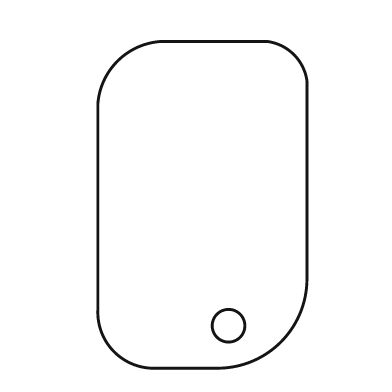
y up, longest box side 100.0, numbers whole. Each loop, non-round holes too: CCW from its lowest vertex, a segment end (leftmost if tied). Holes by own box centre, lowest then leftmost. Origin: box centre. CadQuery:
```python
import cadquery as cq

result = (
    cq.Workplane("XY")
    .moveTo(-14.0, -50.0)
    .lineTo(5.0, -50.0)
    .threePointArc((24.0, -42.0), (32.0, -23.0))
    .lineTo(32.0, 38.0)
    .threePointArc((28.0, 46.0), (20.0, 50.0))
    .lineTo(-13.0, 50.0)
    .threePointArc((-26.0, 44.0), (-32.0, 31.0))
    .lineTo(-32.0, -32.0)
    .threePointArc((-27.0, -45.0), (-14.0, -50.0))
    .close()
    .moveTo(8.0, -37.0)
    .circle(5.0)
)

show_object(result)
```